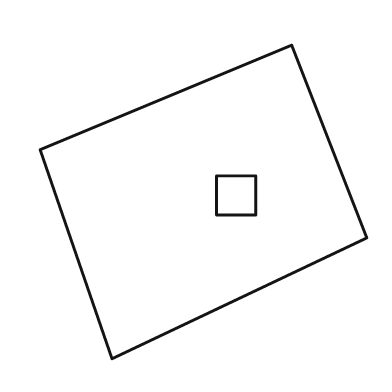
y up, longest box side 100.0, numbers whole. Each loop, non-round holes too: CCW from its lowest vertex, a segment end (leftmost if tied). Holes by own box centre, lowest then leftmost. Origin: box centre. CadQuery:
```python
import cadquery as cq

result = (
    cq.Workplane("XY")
    .moveTo(-28.0, -48.0)
    .lineTo(50.0, -11.0)
    .lineTo(27.0, 48.0)
    .lineTo(-50.0, 16.0)
    .close()
    .moveTo(4.0, -4.0)
    .lineTo(16.0, -4.0)
    .lineTo(16.0, 8.0)
    .lineTo(4.0, 8.0)
    .close()
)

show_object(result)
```